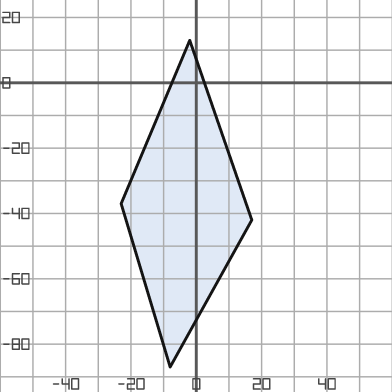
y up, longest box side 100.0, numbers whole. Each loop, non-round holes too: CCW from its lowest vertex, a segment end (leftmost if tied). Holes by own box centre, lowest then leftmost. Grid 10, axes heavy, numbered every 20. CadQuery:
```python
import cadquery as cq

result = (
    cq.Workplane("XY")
    .moveTo(-8.0, -87.0)
    .lineTo(17.0, -42.0)
    .lineTo(-2.0, 13.0)
    .lineTo(-23.0, -37.0)
    .close()
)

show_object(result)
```